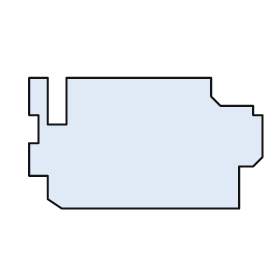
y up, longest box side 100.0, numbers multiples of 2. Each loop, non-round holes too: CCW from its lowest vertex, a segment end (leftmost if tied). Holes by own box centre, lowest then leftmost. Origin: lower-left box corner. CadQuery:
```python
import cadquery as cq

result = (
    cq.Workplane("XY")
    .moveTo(14.0, 0.0)
    .lineTo(90.0, 0.0)
    .lineTo(90.0, 18.0)
    .lineTo(96.0, 18.0)
    .lineTo(100.0, 22.0)
    .lineTo(100.0, 40.0)
    .lineTo(96.0, 40.0)
    .lineTo(96.0, 44.0)
    .lineTo(82.0, 44.0)
    .lineTo(78.0, 48.0)
    .lineTo(78.0, 56.0)
    .lineTo(16.0, 56.0)
    .lineTo(16.0, 36.0)
    .lineTo(8.0, 36.0)
    .lineTo(8.0, 56.0)
    .lineTo(0.0, 56.0)
    .lineTo(0.0, 40.0)
    .lineTo(4.0, 40.0)
    .lineTo(4.0, 28.0)
    .lineTo(0.0, 28.0)
    .lineTo(0.0, 14.0)
    .lineTo(8.0, 14.0)
    .lineTo(8.0, 4.0)
    .close()
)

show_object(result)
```